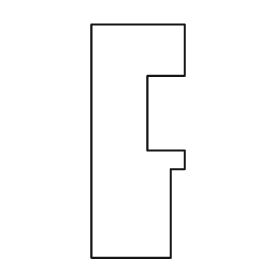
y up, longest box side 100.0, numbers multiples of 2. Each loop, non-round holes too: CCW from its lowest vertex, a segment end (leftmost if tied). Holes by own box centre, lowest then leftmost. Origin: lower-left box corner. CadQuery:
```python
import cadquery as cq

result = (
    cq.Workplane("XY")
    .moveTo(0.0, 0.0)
    .lineTo(34.0, 0.0)
    .lineTo(34.0, 38.0)
    .lineTo(40.0, 38.0)
    .lineTo(40.0, 46.0)
    .lineTo(24.0, 46.0)
    .lineTo(24.0, 78.0)
    .lineTo(40.0, 78.0)
    .lineTo(40.0, 100.0)
    .lineTo(0.0, 100.0)
    .close()
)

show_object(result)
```